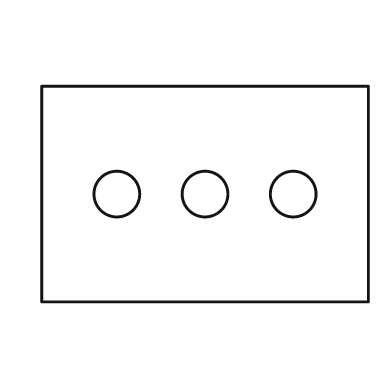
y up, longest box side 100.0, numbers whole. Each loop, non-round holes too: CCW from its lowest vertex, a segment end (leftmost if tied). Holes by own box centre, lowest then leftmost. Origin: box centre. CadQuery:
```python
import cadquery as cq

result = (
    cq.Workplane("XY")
    .moveTo(-50.0, -33.0)
    .lineTo(50.0, -33.0)
    .lineTo(50.0, 33.0)
    .lineTo(-50.0, 33.0)
    .close()
    .moveTo(-27.0, 0.0)
    .circle(7.0)
    .moveTo(0.0, 0.0)
    .circle(7.0)
    .moveTo(27.0, 0.0)
    .circle(7.0)
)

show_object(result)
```